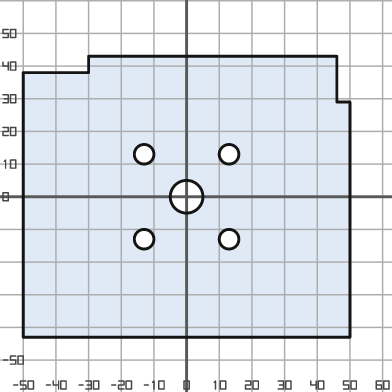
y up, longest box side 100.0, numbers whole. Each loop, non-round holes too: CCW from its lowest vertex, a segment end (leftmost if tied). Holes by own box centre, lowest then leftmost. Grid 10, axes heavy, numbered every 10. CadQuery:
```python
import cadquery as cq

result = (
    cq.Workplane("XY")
    .moveTo(-50.0, -43.0)
    .lineTo(50.0, -43.0)
    .lineTo(50.0, 29.0)
    .lineTo(46.0, 29.0)
    .lineTo(46.0, 43.0)
    .lineTo(-30.0, 43.0)
    .lineTo(-30.0, 38.0)
    .lineTo(-50.0, 38.0)
    .close()
    .moveTo(-13.0, -13.0)
    .circle(3.0)
    .moveTo(13.0, -13.0)
    .circle(3.0)
    .moveTo(0.0, 0.0)
    .circle(5.0)
    .moveTo(-13.0, 13.0)
    .circle(3.0)
    .moveTo(13.0, 13.0)
    .circle(3.0)
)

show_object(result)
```